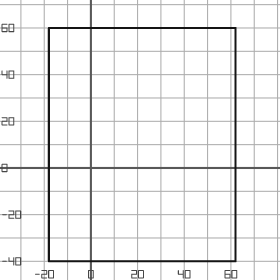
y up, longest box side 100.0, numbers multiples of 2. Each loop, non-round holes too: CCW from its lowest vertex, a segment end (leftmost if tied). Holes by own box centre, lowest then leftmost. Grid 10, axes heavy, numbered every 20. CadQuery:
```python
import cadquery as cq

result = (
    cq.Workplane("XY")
    .moveTo(-18.0, -40.0)
    .lineTo(62.0, -40.0)
    .lineTo(62.0, 60.0)
    .lineTo(-18.0, 60.0)
    .close()
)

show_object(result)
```